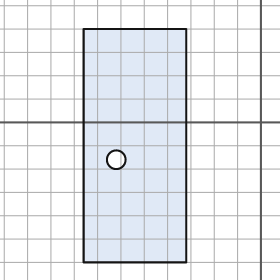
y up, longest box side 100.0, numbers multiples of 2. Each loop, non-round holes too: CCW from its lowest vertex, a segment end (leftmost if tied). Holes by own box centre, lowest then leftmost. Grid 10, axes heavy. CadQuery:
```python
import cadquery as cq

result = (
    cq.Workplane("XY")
    .moveTo(-76.0, -60.0)
    .lineTo(-32.0, -60.0)
    .lineTo(-32.0, 40.0)
    .lineTo(-76.0, 40.0)
    .close()
    .moveTo(-62.0, -16.0)
    .circle(4.0)
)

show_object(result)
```